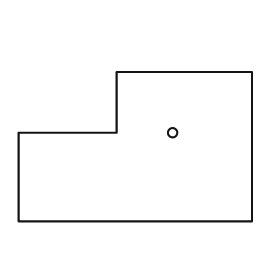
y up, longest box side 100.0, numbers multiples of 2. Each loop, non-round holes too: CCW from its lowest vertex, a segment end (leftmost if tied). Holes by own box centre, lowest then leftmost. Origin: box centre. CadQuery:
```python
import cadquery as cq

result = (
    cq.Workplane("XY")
    .moveTo(-50.0, -32.0)
    .lineTo(50.0, -32.0)
    .lineTo(50.0, 32.0)
    .lineTo(-8.0, 32.0)
    .lineTo(-8.0, 6.0)
    .lineTo(-50.0, 6.0)
    .close()
    .moveTo(16.0, 6.0)
    .circle(2.0)
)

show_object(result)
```